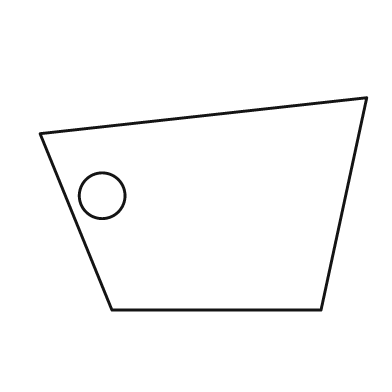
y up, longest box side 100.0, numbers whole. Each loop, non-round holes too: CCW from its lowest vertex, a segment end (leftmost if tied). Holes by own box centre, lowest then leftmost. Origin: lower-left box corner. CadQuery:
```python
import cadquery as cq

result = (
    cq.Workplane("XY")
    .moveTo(22.0, 0.0)
    .lineTo(86.0, 0.0)
    .lineTo(100.0, 65.0)
    .lineTo(0.0, 54.0)
    .close()
    .moveTo(19.0, 35.0)
    .circle(7.0)
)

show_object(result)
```